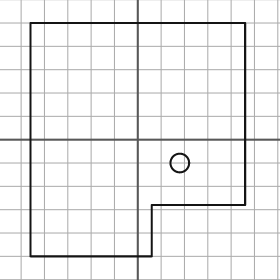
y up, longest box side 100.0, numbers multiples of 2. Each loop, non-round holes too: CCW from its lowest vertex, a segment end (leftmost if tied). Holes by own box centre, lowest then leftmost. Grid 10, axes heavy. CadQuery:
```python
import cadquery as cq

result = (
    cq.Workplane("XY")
    .moveTo(-46.0, -50.0)
    .lineTo(6.0, -50.0)
    .lineTo(6.0, -28.0)
    .lineTo(46.0, -28.0)
    .lineTo(46.0, 50.0)
    .lineTo(-46.0, 50.0)
    .close()
    .moveTo(18.0, -10.0)
    .circle(4.0)
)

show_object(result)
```